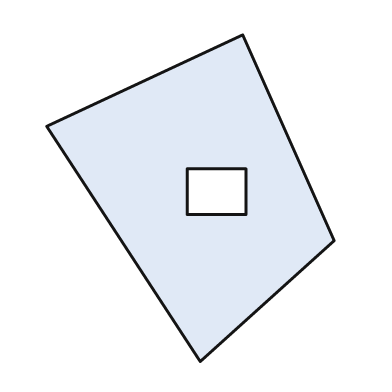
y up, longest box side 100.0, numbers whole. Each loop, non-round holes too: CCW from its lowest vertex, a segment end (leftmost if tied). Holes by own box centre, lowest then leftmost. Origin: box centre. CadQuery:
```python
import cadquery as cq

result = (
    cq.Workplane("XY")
    .moveTo(3.0, -50.0)
    .lineTo(44.0, -13.0)
    .lineTo(16.0, 50.0)
    .lineTo(-44.0, 22.0)
    .close()
    .moveTo(-1.0, -5.0)
    .lineTo(17.0, -5.0)
    .lineTo(17.0, 9.0)
    .lineTo(-1.0, 9.0)
    .close()
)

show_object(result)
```